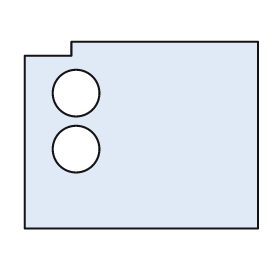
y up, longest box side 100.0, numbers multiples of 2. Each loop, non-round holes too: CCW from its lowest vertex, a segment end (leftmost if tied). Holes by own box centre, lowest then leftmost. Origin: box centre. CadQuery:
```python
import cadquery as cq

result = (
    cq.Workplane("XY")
    .moveTo(-50.0, -40.0)
    .lineTo(50.0, -40.0)
    .lineTo(50.0, 40.0)
    .lineTo(-30.0, 40.0)
    .lineTo(-30.0, 34.0)
    .lineTo(-50.0, 34.0)
    .close()
    .moveTo(-28.0, -6.0)
    .circle(10.0)
    .moveTo(-28.0, 18.0)
    .circle(10.0)
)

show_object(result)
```